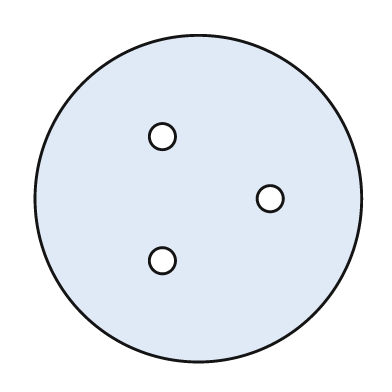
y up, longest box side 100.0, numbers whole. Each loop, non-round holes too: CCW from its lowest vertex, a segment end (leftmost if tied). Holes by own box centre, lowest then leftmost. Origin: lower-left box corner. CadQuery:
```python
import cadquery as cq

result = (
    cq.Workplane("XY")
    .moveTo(50.0, 50.0)
    .circle(50.0)
    .moveTo(39.0, 31.0)
    .circle(4.0)
    .moveTo(72.0, 50.0)
    .circle(4.0)
    .moveTo(39.0, 69.0)
    .circle(4.0)
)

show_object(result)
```